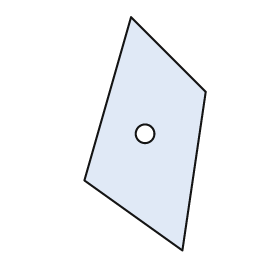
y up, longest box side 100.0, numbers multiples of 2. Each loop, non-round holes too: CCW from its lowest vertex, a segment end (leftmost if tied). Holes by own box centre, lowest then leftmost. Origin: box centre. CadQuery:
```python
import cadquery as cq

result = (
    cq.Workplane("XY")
    .moveTo(16.0, -50.0)
    .lineTo(26.0, 18.0)
    .lineTo(-6.0, 50.0)
    .lineTo(-26.0, -20.0)
    .close()
    .moveTo(0.0, 0.0)
    .circle(4.0)
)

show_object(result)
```